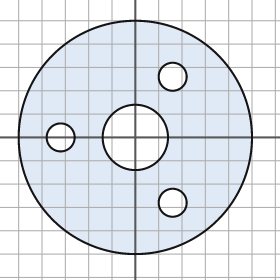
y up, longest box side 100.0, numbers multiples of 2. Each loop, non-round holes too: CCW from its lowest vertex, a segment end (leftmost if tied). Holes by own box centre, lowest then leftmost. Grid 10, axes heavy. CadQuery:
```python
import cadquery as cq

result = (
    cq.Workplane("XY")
    .moveTo(0.0, 0.0)
    .circle(50.0)
    .moveTo(16.0, -28.0)
    .circle(6.0)
    .moveTo(-32.0, 0.0)
    .circle(6.0)
    .moveTo(0.0, 0.0)
    .circle(14.0)
    .moveTo(16.0, 26.0)
    .circle(6.0)
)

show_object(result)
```